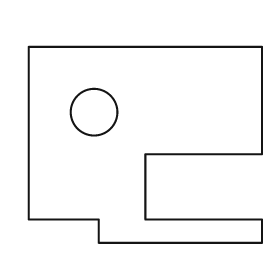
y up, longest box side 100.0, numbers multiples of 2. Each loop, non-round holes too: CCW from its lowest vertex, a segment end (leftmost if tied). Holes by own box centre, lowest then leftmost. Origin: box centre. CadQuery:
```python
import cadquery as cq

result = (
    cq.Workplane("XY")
    .moveTo(-20.0, -42.0)
    .lineTo(50.0, -42.0)
    .lineTo(50.0, -32.0)
    .lineTo(0.0, -32.0)
    .lineTo(0.0, -4.0)
    .lineTo(50.0, -4.0)
    .lineTo(50.0, 42.0)
    .lineTo(-50.0, 42.0)
    .lineTo(-50.0, -32.0)
    .lineTo(-20.0, -32.0)
    .close()
    .moveTo(-22.0, 14.0)
    .circle(10.0)
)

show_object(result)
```